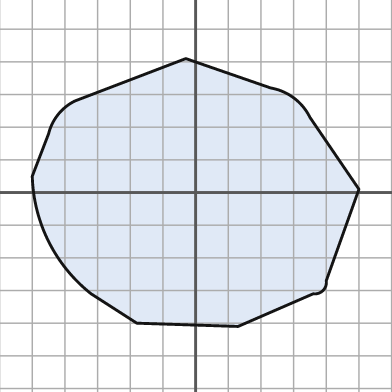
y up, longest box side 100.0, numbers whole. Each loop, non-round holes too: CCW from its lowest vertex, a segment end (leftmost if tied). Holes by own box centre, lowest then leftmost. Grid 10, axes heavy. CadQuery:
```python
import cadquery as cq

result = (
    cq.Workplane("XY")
    .moveTo(13.0, -41.0)
    .lineTo(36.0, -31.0)
    .threePointArc((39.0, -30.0), (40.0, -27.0))
    .lineTo(50.0, 1.0)
    .lineTo(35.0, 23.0)
    .threePointArc((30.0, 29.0), (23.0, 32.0))
    .lineTo(-3.0, 41.0)
    .lineTo(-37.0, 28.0)
    .threePointArc((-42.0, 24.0), (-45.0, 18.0))
    .lineTo(-50.0, 5.0)
    .threePointArc((-45.0, -15.0), (-32.0, -31.0))
    .lineTo(-18.0, -40.0)
    .close()
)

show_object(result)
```